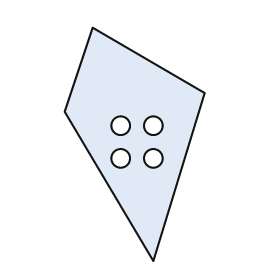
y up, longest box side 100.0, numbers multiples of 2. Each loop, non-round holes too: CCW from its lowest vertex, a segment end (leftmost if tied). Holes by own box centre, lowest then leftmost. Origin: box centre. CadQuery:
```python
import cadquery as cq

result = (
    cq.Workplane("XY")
    .moveTo(8.0, -50.0)
    .lineTo(30.0, 22.0)
    .lineTo(-18.0, 50.0)
    .lineTo(-30.0, 14.0)
    .close()
    .moveTo(-6.0, -6.0)
    .circle(4.0)
    .moveTo(8.0, -6.0)
    .circle(4.0)
    .moveTo(-6.0, 8.0)
    .circle(4.0)
    .moveTo(8.0, 8.0)
    .circle(4.0)
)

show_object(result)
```